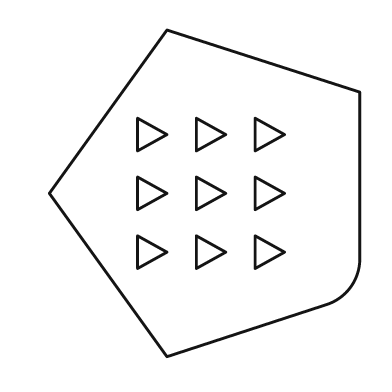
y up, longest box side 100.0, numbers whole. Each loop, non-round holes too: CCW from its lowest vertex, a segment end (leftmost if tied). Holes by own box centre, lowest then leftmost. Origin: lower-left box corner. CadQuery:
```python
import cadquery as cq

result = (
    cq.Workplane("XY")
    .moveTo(36.0, 0.0)
    .lineTo(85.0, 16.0)
    .threePointArc((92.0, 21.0), (95.0, 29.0))
    .lineTo(95.0, 81.0)
    .lineTo(36.0, 100.0)
    .lineTo(0.0, 50.0)
    .close()
    .moveTo(27.0, 27.0)
    .lineTo(36.0, 32.0)
    .lineTo(27.0, 37.0)
    .close()
    .moveTo(45.0, 27.0)
    .lineTo(54.0, 32.0)
    .lineTo(45.0, 37.0)
    .close()
    .moveTo(63.0, 27.0)
    .lineTo(72.0, 32.0)
    .lineTo(63.0, 37.0)
    .close()
    .moveTo(27.0, 45.0)
    .lineTo(36.0, 50.0)
    .lineTo(27.0, 55.0)
    .close()
    .moveTo(45.0, 45.0)
    .lineTo(54.0, 50.0)
    .lineTo(45.0, 55.0)
    .close()
    .moveTo(63.0, 45.0)
    .lineTo(72.0, 50.0)
    .lineTo(63.0, 55.0)
    .close()
    .moveTo(27.0, 63.0)
    .lineTo(36.0, 68.0)
    .lineTo(27.0, 73.0)
    .close()
    .moveTo(45.0, 63.0)
    .lineTo(54.0, 68.0)
    .lineTo(45.0, 73.0)
    .close()
    .moveTo(63.0, 63.0)
    .lineTo(72.0, 68.0)
    .lineTo(63.0, 73.0)
    .close()
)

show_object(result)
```